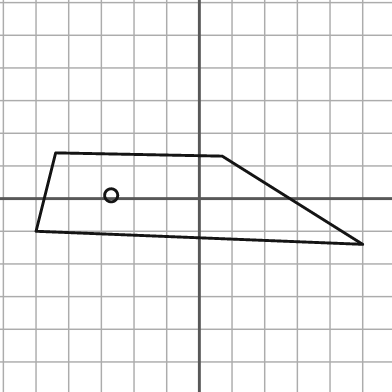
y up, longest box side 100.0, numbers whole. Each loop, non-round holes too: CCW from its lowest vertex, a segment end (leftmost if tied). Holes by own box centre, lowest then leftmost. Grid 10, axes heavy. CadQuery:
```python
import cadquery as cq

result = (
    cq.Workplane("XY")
    .moveTo(50.0, -14.0)
    .lineTo(7.0, 13.0)
    .lineTo(-44.0, 14.0)
    .lineTo(-50.0, -10.0)
    .close()
    .moveTo(-27.0, 1.0)
    .circle(2.0)
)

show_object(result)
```